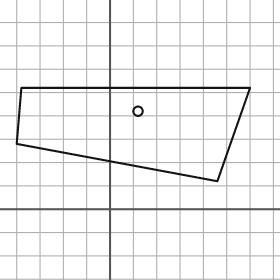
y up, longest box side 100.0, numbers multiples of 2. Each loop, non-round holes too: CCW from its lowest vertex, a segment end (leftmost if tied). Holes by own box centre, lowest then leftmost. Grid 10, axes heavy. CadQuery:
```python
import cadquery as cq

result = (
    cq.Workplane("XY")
    .moveTo(46.0, 12.0)
    .lineTo(60.0, 52.0)
    .lineTo(-38.0, 52.0)
    .lineTo(-40.0, 28.0)
    .close()
    .moveTo(12.0, 42.0)
    .circle(2.0)
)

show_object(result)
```